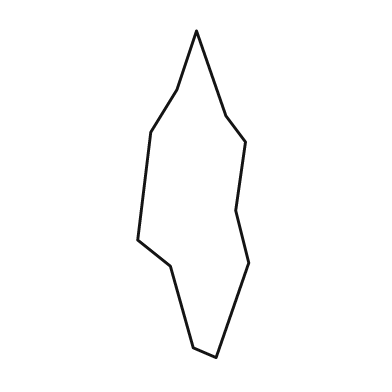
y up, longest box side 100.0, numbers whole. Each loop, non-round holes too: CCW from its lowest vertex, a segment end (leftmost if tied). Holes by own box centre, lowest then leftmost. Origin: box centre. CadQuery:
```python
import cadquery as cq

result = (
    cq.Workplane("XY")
    .moveTo(7.0, -50.0)
    .lineTo(17.0, -21.0)
    .lineTo(13.0, -5.0)
    .lineTo(16.0, 16.0)
    .lineTo(10.0, 24.0)
    .lineTo(1.0, 50.0)
    .lineTo(-5.0, 32.0)
    .lineTo(-13.0, 19.0)
    .lineTo(-17.0, -14.0)
    .lineTo(-7.0, -22.0)
    .lineTo(0.0, -47.0)
    .close()
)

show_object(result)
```